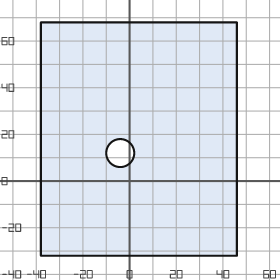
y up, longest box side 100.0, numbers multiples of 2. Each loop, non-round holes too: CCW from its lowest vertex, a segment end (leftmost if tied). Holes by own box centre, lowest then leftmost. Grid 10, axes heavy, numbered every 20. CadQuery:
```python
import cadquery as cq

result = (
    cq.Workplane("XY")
    .moveTo(-38.0, -32.0)
    .lineTo(46.0, -32.0)
    .lineTo(46.0, 68.0)
    .lineTo(-38.0, 68.0)
    .close()
    .moveTo(-4.0, 12.0)
    .circle(6.0)
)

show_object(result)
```